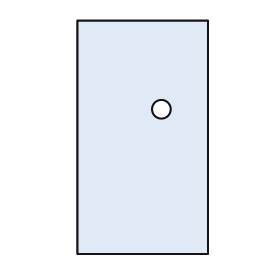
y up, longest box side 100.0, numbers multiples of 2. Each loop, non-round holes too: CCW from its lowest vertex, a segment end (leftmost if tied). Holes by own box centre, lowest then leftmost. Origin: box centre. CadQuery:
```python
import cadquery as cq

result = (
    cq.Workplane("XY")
    .moveTo(-28.0, -50.0)
    .lineTo(28.0, -50.0)
    .lineTo(28.0, 50.0)
    .lineTo(-28.0, 50.0)
    .close()
    .moveTo(8.0, 12.0)
    .circle(4.0)
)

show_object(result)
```